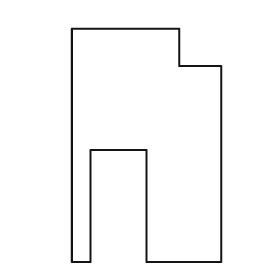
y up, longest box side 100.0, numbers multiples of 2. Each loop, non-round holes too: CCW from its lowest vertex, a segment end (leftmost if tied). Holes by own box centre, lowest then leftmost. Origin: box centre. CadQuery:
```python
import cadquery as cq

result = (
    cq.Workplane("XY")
    .moveTo(-32.0, -50.0)
    .lineTo(-24.0, -50.0)
    .lineTo(-24.0, -2.0)
    .lineTo(0.0, -2.0)
    .lineTo(0.0, -50.0)
    .lineTo(32.0, -50.0)
    .lineTo(32.0, 34.0)
    .lineTo(14.0, 34.0)
    .lineTo(14.0, 50.0)
    .lineTo(-32.0, 50.0)
    .close()
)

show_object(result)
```